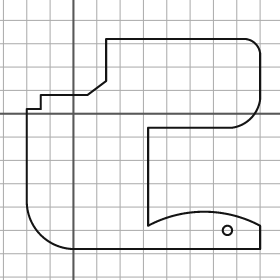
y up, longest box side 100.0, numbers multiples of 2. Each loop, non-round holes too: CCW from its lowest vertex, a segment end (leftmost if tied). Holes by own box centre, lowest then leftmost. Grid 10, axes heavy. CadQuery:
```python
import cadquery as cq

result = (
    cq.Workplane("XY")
    .moveTo(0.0, -58.0)
    .lineTo(80.0, -58.0)
    .lineTo(80.0, -48.0)
    .threePointArc((56.0, -42.0), (32.0, -48.0))
    .lineTo(32.0, -6.0)
    .lineTo(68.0, -6.0)
    .threePointArc((76.0, -2.0), (80.0, 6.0))
    .lineTo(80.0, 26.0)
    .threePointArc((78.0, 30.0), (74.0, 32.0))
    .lineTo(14.0, 32.0)
    .lineTo(14.0, 14.0)
    .lineTo(6.0, 8.0)
    .lineTo(-14.0, 8.0)
    .lineTo(-14.0, 2.0)
    .lineTo(-20.0, 2.0)
    .lineTo(-20.0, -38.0)
    .threePointArc((-14.0, -52.0), (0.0, -58.0))
    .close()
    .moveTo(66.0, -50.0)
    .circle(2.0)
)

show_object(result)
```